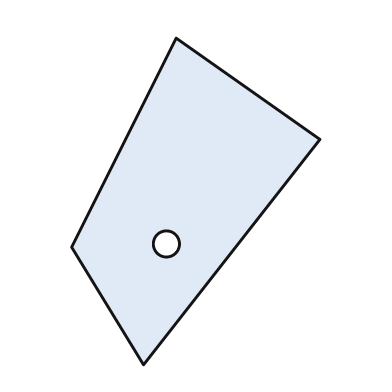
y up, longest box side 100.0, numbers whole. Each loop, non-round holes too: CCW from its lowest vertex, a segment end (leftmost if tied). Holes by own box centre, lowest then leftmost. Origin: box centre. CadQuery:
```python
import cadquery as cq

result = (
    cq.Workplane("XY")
    .moveTo(-16.0, -50.0)
    .lineTo(38.0, 19.0)
    .lineTo(-6.0, 50.0)
    .lineTo(-38.0, -14.0)
    .close()
    .moveTo(-9.0, -13.0)
    .circle(4.0)
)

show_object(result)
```